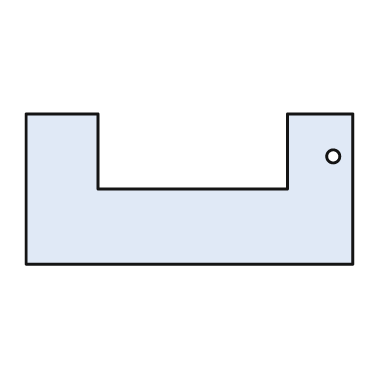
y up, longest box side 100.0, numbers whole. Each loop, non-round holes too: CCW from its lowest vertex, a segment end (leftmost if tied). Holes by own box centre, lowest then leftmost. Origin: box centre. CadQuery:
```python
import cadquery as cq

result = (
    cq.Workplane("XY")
    .moveTo(-50.0, -23.0)
    .lineTo(50.0, -23.0)
    .lineTo(50.0, 23.0)
    .lineTo(30.0, 23.0)
    .lineTo(30.0, 0.0)
    .lineTo(-28.0, 0.0)
    .lineTo(-28.0, 23.0)
    .lineTo(-50.0, 23.0)
    .close()
    .moveTo(44.0, 10.0)
    .circle(2.0)
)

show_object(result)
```